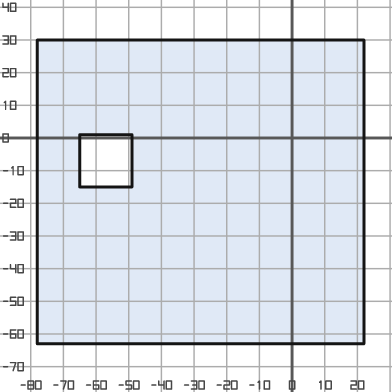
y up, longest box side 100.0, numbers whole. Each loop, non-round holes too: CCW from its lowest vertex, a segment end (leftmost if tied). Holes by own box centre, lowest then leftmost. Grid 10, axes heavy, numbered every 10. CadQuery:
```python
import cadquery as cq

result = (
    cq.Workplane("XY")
    .moveTo(-78.0, -63.0)
    .lineTo(22.0, -63.0)
    .lineTo(22.0, 30.0)
    .lineTo(-78.0, 30.0)
    .close()
    .moveTo(-65.0, -15.0)
    .lineTo(-49.0, -15.0)
    .lineTo(-49.0, 1.0)
    .lineTo(-65.0, 1.0)
    .close()
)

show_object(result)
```